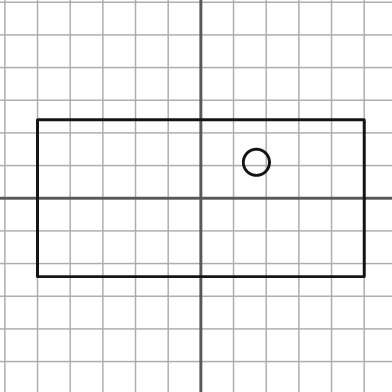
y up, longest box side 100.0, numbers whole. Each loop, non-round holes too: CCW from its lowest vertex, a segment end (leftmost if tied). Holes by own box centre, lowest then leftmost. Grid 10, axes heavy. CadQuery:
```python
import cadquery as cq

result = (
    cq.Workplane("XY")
    .moveTo(-50.0, -24.0)
    .lineTo(50.0, -24.0)
    .lineTo(50.0, 24.0)
    .lineTo(-50.0, 24.0)
    .close()
    .moveTo(17.0, 11.0)
    .circle(4.0)
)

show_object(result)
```